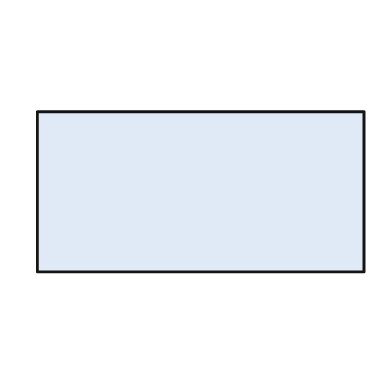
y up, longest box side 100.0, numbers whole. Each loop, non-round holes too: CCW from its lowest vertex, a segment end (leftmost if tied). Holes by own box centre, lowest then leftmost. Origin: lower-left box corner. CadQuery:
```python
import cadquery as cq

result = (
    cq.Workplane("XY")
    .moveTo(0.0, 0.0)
    .lineTo(100.0, 0.0)
    .lineTo(100.0, 49.0)
    .lineTo(0.0, 49.0)
    .close()
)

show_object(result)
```